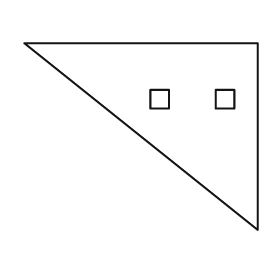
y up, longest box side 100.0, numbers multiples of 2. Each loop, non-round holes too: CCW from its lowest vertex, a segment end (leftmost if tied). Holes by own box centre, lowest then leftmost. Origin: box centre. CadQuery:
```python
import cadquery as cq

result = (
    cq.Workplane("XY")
    .moveTo(50.0, -40.0)
    .lineTo(50.0, 40.0)
    .lineTo(-50.0, 40.0)
    .close()
    .moveTo(4.0, 12.0)
    .lineTo(12.0, 12.0)
    .lineTo(12.0, 20.0)
    .lineTo(4.0, 20.0)
    .close()
    .moveTo(32.0, 12.0)
    .lineTo(40.0, 12.0)
    .lineTo(40.0, 20.0)
    .lineTo(32.0, 20.0)
    .close()
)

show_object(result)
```